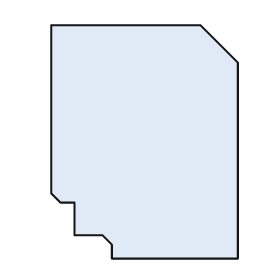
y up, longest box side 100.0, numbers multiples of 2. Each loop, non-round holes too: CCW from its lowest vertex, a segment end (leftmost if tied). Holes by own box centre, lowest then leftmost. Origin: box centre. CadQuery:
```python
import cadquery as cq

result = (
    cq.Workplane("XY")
    .moveTo(-14.0, -50.0)
    .lineTo(40.0, -50.0)
    .lineTo(40.0, 34.0)
    .lineTo(24.0, 50.0)
    .lineTo(-40.0, 50.0)
    .lineTo(-40.0, -22.0)
    .lineTo(-36.0, -26.0)
    .lineTo(-30.0, -26.0)
    .lineTo(-30.0, -40.0)
    .lineTo(-18.0, -40.0)
    .lineTo(-14.0, -44.0)
    .close()
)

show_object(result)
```